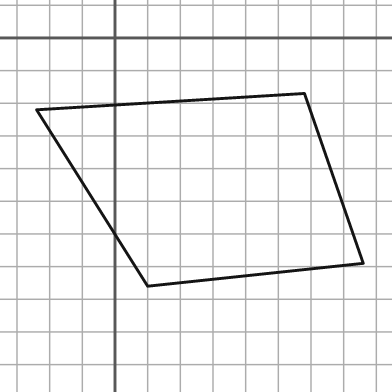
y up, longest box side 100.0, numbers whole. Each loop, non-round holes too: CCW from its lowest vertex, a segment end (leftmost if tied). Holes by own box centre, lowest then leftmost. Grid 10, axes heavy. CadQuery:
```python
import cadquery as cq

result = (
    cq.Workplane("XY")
    .moveTo(10.0, -76.0)
    .lineTo(76.0, -69.0)
    .lineTo(58.0, -17.0)
    .lineTo(-24.0, -22.0)
    .close()
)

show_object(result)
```